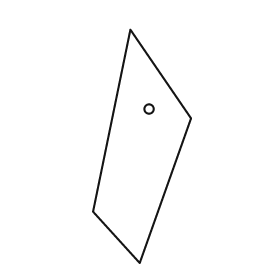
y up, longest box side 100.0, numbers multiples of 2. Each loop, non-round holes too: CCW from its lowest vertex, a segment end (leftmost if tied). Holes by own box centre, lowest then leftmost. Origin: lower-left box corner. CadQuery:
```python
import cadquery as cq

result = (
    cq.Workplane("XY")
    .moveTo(20.0, 0.0)
    .lineTo(42.0, 62.0)
    .lineTo(16.0, 100.0)
    .lineTo(0.0, 22.0)
    .close()
    .moveTo(24.0, 66.0)
    .circle(2.0)
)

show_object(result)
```